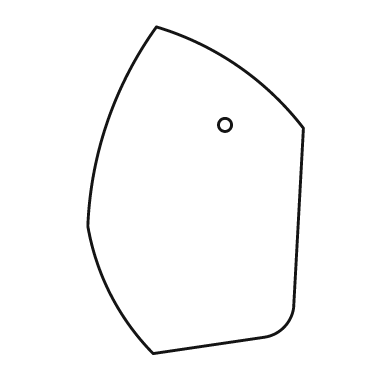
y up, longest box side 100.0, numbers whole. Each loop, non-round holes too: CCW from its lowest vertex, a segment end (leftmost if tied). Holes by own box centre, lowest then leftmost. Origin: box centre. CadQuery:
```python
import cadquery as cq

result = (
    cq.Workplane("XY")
    .moveTo(-13.0, -50.0)
    .lineTo(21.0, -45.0)
    .threePointArc((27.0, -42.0), (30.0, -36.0))
    .lineTo(33.0, 19.0)
    .threePointArc((13.0, 38.0), (-12.0, 50.0))
    .threePointArc((-27.0, 21.0), (-33.0, -11.0))
    .threePointArc((-26.0, -32.0), (-13.0, -50.0))
    .close()
    .moveTo(9.0, 20.0)
    .circle(2.0)
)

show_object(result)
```